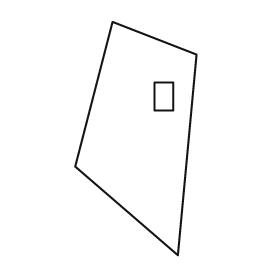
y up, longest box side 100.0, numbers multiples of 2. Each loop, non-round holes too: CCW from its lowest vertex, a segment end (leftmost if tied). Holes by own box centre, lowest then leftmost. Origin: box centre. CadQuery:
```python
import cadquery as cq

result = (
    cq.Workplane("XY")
    .moveTo(18.0, -50.0)
    .lineTo(26.0, 36.0)
    .lineTo(-10.0, 50.0)
    .lineTo(-26.0, -12.0)
    .close()
    .moveTo(8.0, 12.0)
    .lineTo(16.0, 12.0)
    .lineTo(16.0, 24.0)
    .lineTo(8.0, 24.0)
    .close()
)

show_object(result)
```